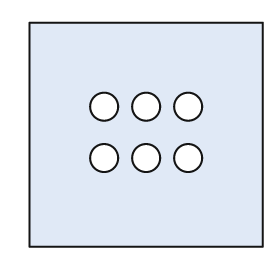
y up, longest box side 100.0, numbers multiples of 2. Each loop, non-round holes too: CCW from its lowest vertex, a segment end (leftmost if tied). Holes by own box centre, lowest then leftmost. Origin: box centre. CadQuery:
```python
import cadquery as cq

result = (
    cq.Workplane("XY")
    .moveTo(-50.0, -48.0)
    .lineTo(50.0, -48.0)
    .lineTo(50.0, 48.0)
    .lineTo(-50.0, 48.0)
    .close()
    .moveTo(-18.0, -10.0)
    .circle(6.0)
    .moveTo(0.0, -10.0)
    .circle(6.0)
    .moveTo(18.0, -10.0)
    .circle(6.0)
    .moveTo(-18.0, 12.0)
    .circle(6.0)
    .moveTo(0.0, 12.0)
    .circle(6.0)
    .moveTo(18.0, 12.0)
    .circle(6.0)
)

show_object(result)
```